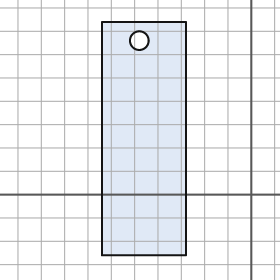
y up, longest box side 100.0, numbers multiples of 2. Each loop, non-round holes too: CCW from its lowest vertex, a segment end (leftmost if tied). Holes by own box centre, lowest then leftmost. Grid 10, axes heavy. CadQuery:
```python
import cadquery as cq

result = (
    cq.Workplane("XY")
    .moveTo(-64.0, -26.0)
    .lineTo(-28.0, -26.0)
    .lineTo(-28.0, 74.0)
    .lineTo(-64.0, 74.0)
    .close()
    .moveTo(-48.0, 66.0)
    .circle(4.0)
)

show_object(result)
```